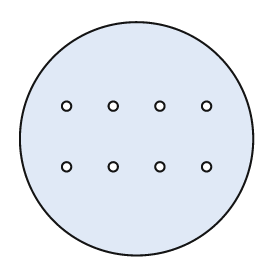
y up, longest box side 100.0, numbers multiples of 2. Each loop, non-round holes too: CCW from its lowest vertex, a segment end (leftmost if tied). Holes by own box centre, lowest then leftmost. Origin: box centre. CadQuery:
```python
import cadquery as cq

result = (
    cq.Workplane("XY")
    .moveTo(0.0, 0.0)
    .circle(50.0)
    .moveTo(-30.0, -12.0)
    .circle(2.0)
    .moveTo(-10.0, -12.0)
    .circle(2.0)
    .moveTo(10.0, -12.0)
    .circle(2.0)
    .moveTo(30.0, -12.0)
    .circle(2.0)
    .moveTo(-30.0, 14.0)
    .circle(2.0)
    .moveTo(-10.0, 14.0)
    .circle(2.0)
    .moveTo(10.0, 14.0)
    .circle(2.0)
    .moveTo(30.0, 14.0)
    .circle(2.0)
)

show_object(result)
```